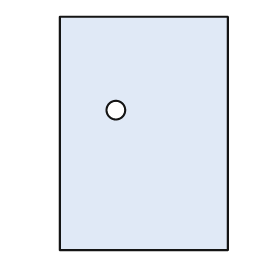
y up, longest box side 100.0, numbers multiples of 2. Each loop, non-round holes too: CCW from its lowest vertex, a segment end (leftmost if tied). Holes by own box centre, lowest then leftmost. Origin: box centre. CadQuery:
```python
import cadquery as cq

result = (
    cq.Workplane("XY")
    .moveTo(-36.0, -50.0)
    .lineTo(36.0, -50.0)
    .lineTo(36.0, 50.0)
    .lineTo(-36.0, 50.0)
    .close()
    .moveTo(-12.0, 10.0)
    .circle(4.0)
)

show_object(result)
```